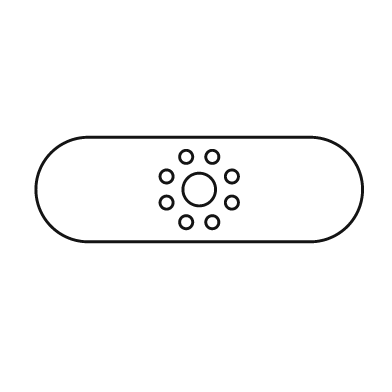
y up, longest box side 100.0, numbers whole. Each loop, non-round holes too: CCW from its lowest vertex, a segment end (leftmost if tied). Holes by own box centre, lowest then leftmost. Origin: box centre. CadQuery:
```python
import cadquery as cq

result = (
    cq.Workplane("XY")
    .moveTo(-34.0, -16.0)
    .lineTo(34.0, -16.0)
    .threePointArc((50.0, 0.0), (34.0, 16.0))
    .lineTo(-34.0, 16.0)
    .threePointArc((-50.0, 0.0), (-34.0, -16.0))
    .close()
    .moveTo(-4.0, -10.0)
    .circle(2.0)
    .moveTo(4.0, -10.0)
    .circle(2.0)
    .moveTo(-10.0, -4.0)
    .circle(2.0)
    .moveTo(10.0, -4.0)
    .circle(2.0)
    .moveTo(0.0, 0.0)
    .circle(5.0)
    .moveTo(-10.0, 4.0)
    .circle(2.0)
    .moveTo(10.0, 4.0)
    .circle(2.0)
    .moveTo(-4.0, 10.0)
    .circle(2.0)
    .moveTo(4.0, 10.0)
    .circle(2.0)
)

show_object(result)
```